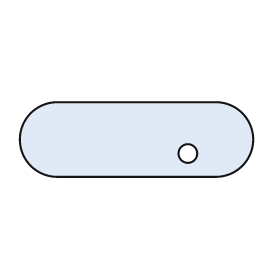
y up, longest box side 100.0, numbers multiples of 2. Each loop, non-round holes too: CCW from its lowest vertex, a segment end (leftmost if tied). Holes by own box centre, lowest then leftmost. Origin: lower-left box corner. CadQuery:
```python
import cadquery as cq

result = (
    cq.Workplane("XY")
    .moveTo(16.0, 0.0)
    .lineTo(84.0, 0.0)
    .threePointArc((100.0, 16.0), (84.0, 32.0))
    .lineTo(16.0, 32.0)
    .threePointArc((0.0, 16.0), (16.0, 0.0))
    .close()
    .moveTo(72.0, 10.0)
    .circle(4.0)
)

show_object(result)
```